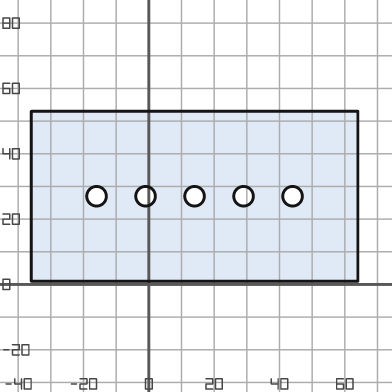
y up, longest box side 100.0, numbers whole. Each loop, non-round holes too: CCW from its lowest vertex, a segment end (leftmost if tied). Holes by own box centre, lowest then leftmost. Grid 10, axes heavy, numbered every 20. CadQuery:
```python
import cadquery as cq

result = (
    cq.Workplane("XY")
    .moveTo(-36.0, 1.0)
    .lineTo(64.0, 1.0)
    .lineTo(64.0, 53.0)
    .lineTo(-36.0, 53.0)
    .close()
    .moveTo(-16.0, 27.0)
    .circle(3.0)
    .moveTo(-1.0, 27.0)
    .circle(3.0)
    .moveTo(14.0, 27.0)
    .circle(3.0)
    .moveTo(29.0, 27.0)
    .circle(3.0)
    .moveTo(44.0, 27.0)
    .circle(3.0)
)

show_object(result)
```